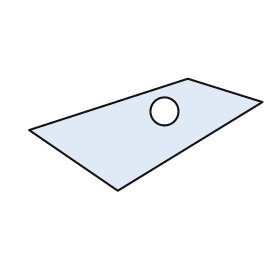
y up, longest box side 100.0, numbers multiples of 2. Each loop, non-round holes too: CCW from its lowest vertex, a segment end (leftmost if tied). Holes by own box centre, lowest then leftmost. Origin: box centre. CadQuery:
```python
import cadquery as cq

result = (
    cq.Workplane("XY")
    .moveTo(-12.0, -24.0)
    .lineTo(50.0, 14.0)
    .lineTo(18.0, 24.0)
    .lineTo(-50.0, 2.0)
    .close()
    .moveTo(8.0, 10.0)
    .circle(6.0)
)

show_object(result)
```